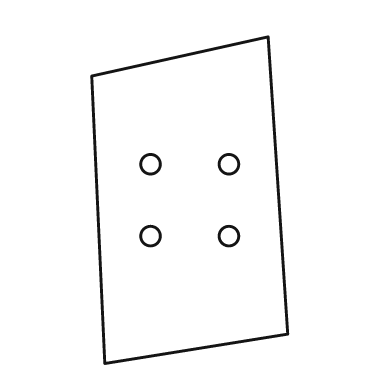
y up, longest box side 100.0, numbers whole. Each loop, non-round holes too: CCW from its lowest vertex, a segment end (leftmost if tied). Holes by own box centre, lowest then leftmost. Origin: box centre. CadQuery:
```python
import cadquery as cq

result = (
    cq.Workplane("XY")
    .moveTo(-26.0, -50.0)
    .lineTo(30.0, -41.0)
    .lineTo(24.0, 50.0)
    .lineTo(-30.0, 38.0)
    .close()
    .moveTo(-12.0, -11.0)
    .circle(3.0)
    .moveTo(12.0, -11.0)
    .circle(3.0)
    .moveTo(-12.0, 11.0)
    .circle(3.0)
    .moveTo(12.0, 11.0)
    .circle(3.0)
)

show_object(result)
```